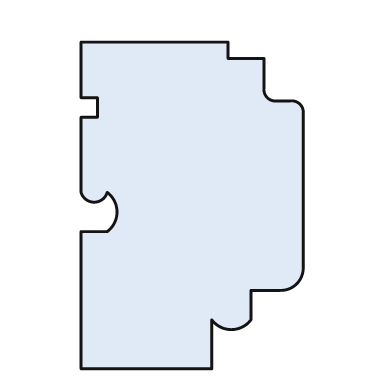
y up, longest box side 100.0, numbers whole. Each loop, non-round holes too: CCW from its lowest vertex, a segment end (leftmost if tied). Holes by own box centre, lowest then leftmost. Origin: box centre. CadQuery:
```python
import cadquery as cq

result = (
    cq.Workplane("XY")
    .moveTo(-34.0, -50.0)
    .lineTo(6.0, -50.0)
    .lineTo(6.0, -35.0)
    .threePointArc((12.0, -38.0), (18.0, -35.0))
    .lineTo(18.0, -26.0)
    .lineTo(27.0, -26.0)
    .threePointArc((32.0, -24.0), (34.0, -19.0))
    .lineTo(34.0, 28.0)
    .threePointArc((33.0, 31.0), (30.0, 32.0))
    .lineTo(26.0, 32.0)
    .threePointArc((23.0, 33.0), (22.0, 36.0))
    .lineTo(22.0, 45.0)
    .lineTo(11.0, 45.0)
    .lineTo(11.0, 50.0)
    .lineTo(-34.0, 50.0)
    .lineTo(-34.0, 33.0)
    .lineTo(-29.0, 33.0)
    .lineTo(-29.0, 27.0)
    .lineTo(-34.0, 27.0)
    .lineTo(-34.0, 4.0)
    .threePointArc((-30.0, 1.0), (-26.0, 4.0))
    .threePointArc((-23.0, -2.0), (-26.0, -8.0))
    .lineTo(-34.0, -8.0)
    .close()
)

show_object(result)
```